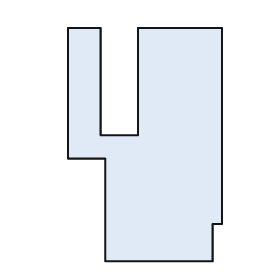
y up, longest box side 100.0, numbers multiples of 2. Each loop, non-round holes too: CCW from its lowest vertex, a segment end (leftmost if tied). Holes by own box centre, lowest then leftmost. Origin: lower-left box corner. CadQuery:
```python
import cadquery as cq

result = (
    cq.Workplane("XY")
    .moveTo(16.0, 0.0)
    .lineTo(62.0, 0.0)
    .lineTo(62.0, 16.0)
    .lineTo(66.0, 16.0)
    .lineTo(66.0, 100.0)
    .lineTo(30.0, 100.0)
    .lineTo(30.0, 54.0)
    .lineTo(14.0, 54.0)
    .lineTo(14.0, 100.0)
    .lineTo(0.0, 100.0)
    .lineTo(0.0, 44.0)
    .lineTo(16.0, 44.0)
    .close()
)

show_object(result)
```